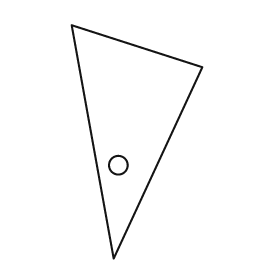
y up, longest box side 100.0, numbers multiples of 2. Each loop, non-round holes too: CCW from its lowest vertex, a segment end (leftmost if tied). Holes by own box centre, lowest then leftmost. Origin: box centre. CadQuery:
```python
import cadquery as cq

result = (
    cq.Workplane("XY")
    .moveTo(-10.0, -50.0)
    .lineTo(28.0, 32.0)
    .lineTo(-28.0, 50.0)
    .close()
    .moveTo(-8.0, -10.0)
    .circle(4.0)
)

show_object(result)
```